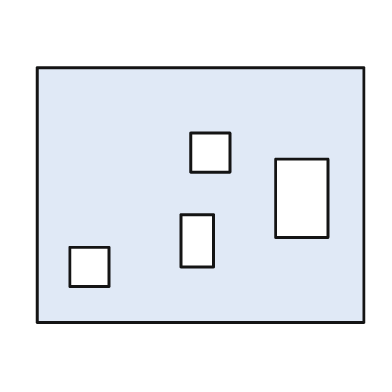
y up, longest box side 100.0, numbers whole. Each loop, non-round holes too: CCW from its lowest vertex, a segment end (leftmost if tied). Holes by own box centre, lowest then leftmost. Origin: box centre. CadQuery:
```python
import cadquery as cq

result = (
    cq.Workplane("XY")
    .moveTo(-50.0, -39.0)
    .lineTo(50.0, -39.0)
    .lineTo(50.0, 39.0)
    .lineTo(-50.0, 39.0)
    .close()
    .moveTo(-40.0, -28.0)
    .lineTo(-28.0, -28.0)
    .lineTo(-28.0, -16.0)
    .lineTo(-40.0, -16.0)
    .close()
    .moveTo(-6.0, -22.0)
    .lineTo(4.0, -22.0)
    .lineTo(4.0, -6.0)
    .lineTo(-6.0, -6.0)
    .close()
    .moveTo(23.0, -13.0)
    .lineTo(39.0, -13.0)
    .lineTo(39.0, 11.0)
    .lineTo(23.0, 11.0)
    .close()
    .moveTo(-3.0, 7.0)
    .lineTo(9.0, 7.0)
    .lineTo(9.0, 19.0)
    .lineTo(-3.0, 19.0)
    .close()
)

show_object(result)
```